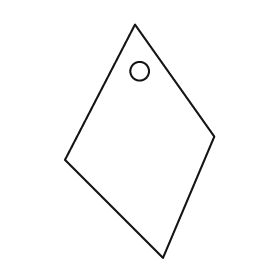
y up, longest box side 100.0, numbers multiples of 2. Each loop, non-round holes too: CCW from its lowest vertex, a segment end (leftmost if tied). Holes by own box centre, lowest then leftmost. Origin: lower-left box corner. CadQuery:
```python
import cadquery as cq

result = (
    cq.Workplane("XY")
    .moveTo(42.0, 0.0)
    .lineTo(64.0, 52.0)
    .lineTo(30.0, 100.0)
    .lineTo(0.0, 42.0)
    .close()
    .moveTo(32.0, 80.0)
    .circle(4.0)
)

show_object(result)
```